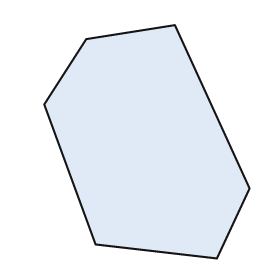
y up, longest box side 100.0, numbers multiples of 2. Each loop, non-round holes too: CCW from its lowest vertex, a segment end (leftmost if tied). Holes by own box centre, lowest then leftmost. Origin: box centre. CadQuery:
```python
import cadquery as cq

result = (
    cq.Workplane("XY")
    .moveTo(30.0, -50.0)
    .lineTo(44.0, -20.0)
    .lineTo(12.0, 50.0)
    .lineTo(-26.0, 44.0)
    .lineTo(-44.0, 16.0)
    .lineTo(-22.0, -44.0)
    .close()
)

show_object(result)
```